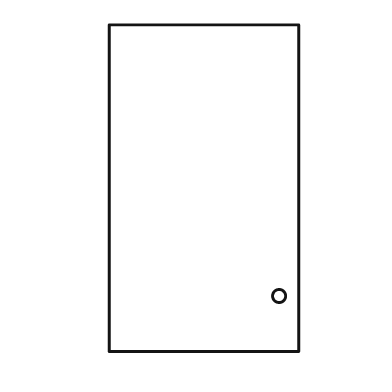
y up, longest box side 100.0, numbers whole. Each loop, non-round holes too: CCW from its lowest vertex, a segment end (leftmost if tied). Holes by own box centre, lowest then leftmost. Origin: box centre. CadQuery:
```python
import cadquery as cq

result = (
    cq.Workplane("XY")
    .moveTo(-29.0, -50.0)
    .lineTo(29.0, -50.0)
    .lineTo(29.0, 50.0)
    .lineTo(-29.0, 50.0)
    .close()
    .moveTo(23.0, -33.0)
    .circle(2.0)
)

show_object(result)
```